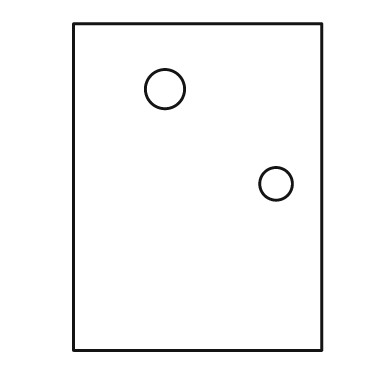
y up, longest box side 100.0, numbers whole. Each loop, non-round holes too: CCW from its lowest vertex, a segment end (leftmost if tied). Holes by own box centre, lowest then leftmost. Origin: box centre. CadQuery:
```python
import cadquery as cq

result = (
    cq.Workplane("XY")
    .moveTo(-38.0, -50.0)
    .lineTo(38.0, -50.0)
    .lineTo(38.0, 50.0)
    .lineTo(-38.0, 50.0)
    .close()
    .moveTo(24.0, 1.0)
    .circle(5.0)
    .moveTo(-10.0, 30.0)
    .circle(6.0)
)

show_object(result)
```